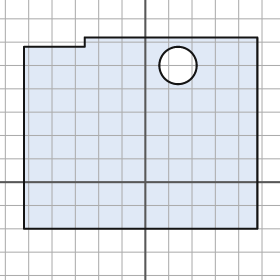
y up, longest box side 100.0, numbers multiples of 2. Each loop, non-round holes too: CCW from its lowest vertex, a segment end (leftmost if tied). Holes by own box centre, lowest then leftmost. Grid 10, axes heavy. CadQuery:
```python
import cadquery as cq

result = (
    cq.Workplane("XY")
    .moveTo(-52.0, -20.0)
    .lineTo(48.0, -20.0)
    .lineTo(48.0, 62.0)
    .lineTo(-26.0, 62.0)
    .lineTo(-26.0, 58.0)
    .lineTo(-52.0, 58.0)
    .close()
    .moveTo(14.0, 50.0)
    .circle(8.0)
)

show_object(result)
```